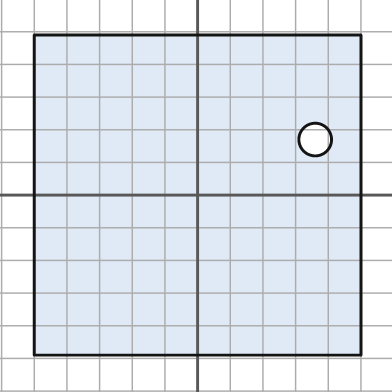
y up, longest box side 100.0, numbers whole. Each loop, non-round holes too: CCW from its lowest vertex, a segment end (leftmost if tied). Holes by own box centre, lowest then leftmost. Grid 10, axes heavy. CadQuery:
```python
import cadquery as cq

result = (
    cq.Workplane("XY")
    .moveTo(-50.0, -49.0)
    .lineTo(50.0, -49.0)
    .lineTo(50.0, 49.0)
    .lineTo(-50.0, 49.0)
    .close()
    .moveTo(36.0, 17.0)
    .circle(5.0)
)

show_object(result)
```